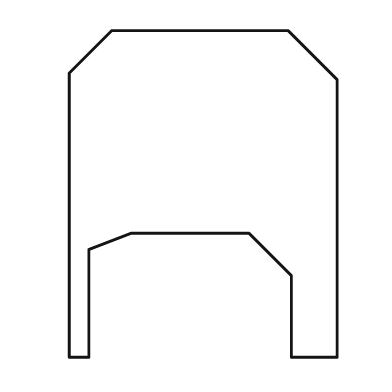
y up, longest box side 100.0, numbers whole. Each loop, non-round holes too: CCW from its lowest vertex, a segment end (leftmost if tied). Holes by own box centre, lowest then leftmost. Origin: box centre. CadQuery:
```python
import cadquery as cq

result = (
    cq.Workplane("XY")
    .moveTo(-41.0, -50.0)
    .lineTo(-35.0, -50.0)
    .lineTo(-35.0, -17.0)
    .lineTo(-22.0, -12.0)
    .lineTo(14.0, -12.0)
    .lineTo(27.0, -25.0)
    .lineTo(27.0, -50.0)
    .lineTo(41.0, -50.0)
    .lineTo(41.0, 35.0)
    .lineTo(26.0, 50.0)
    .lineTo(-28.0, 50.0)
    .lineTo(-41.0, 37.0)
    .close()
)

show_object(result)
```